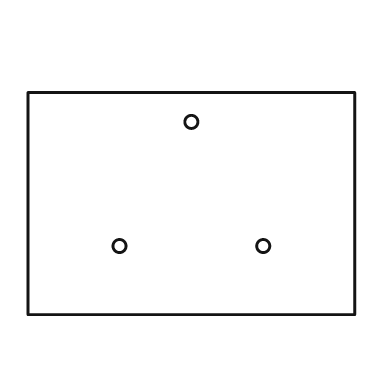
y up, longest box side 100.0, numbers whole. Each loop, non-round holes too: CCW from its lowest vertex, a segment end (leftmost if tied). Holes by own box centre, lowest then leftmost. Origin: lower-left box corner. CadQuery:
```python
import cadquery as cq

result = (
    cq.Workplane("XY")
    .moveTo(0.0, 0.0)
    .lineTo(100.0, 0.0)
    .lineTo(100.0, 68.0)
    .lineTo(0.0, 68.0)
    .close()
    .moveTo(28.0, 21.0)
    .circle(2.0)
    .moveTo(72.0, 21.0)
    .circle(2.0)
    .moveTo(50.0, 59.0)
    .circle(2.0)
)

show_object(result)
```